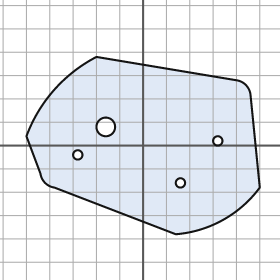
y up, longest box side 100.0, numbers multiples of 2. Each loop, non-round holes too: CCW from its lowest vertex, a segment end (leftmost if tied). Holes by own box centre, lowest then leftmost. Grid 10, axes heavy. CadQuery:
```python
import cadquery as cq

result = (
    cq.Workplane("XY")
    .moveTo(14.0, -38.0)
    .threePointArc((34.0, -32.0), (50.0, -18.0))
    .lineTo(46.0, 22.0)
    .threePointArc((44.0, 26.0), (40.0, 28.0))
    .lineTo(-20.0, 38.0)
    .threePointArc((-38.0, 24.0), (-50.0, 4.0))
    .lineTo(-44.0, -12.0)
    .threePointArc((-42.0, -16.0), (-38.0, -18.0))
    .close()
    .moveTo(16.0, -16.0)
    .circle(2.0)
    .moveTo(-28.0, -4.0)
    .circle(2.0)
    .moveTo(32.0, 2.0)
    .circle(2.0)
    .moveTo(-16.0, 8.0)
    .circle(4.0)
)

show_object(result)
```